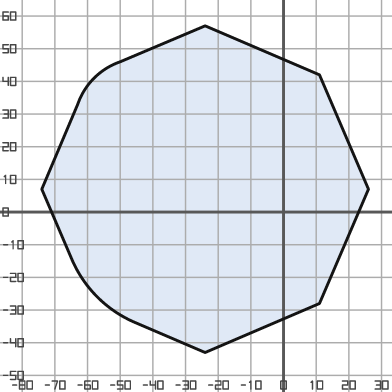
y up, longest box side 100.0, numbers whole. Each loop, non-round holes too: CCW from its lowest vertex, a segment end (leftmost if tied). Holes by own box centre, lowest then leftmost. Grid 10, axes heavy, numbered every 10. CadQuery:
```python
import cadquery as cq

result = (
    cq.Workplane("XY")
    .moveTo(-24.0, -43.0)
    .lineTo(11.0, -28.0)
    .lineTo(26.0, 7.0)
    .lineTo(11.0, 42.0)
    .lineTo(-24.0, 57.0)
    .lineTo(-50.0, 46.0)
    .threePointArc((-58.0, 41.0), (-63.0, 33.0))
    .lineTo(-74.0, 7.0)
    .lineTo(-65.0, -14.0)
    .threePointArc((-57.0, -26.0), (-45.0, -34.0))
    .close()
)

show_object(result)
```